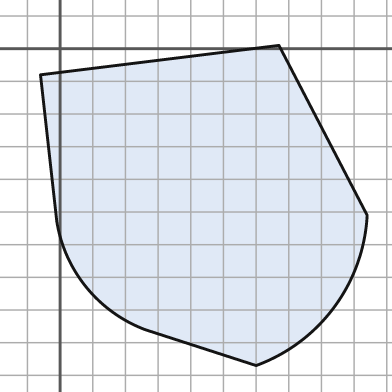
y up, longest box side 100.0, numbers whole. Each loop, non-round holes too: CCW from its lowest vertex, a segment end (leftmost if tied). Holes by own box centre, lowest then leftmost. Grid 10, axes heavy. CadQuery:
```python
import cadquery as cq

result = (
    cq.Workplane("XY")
    .moveTo(60.0, -97.0)
    .threePointArc((84.0, -79.0), (94.0, -51.0))
    .lineTo(67.0, 1.0)
    .lineTo(-6.0, -8.0)
    .lineTo(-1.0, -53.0)
    .threePointArc((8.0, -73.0), (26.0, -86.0))
    .close()
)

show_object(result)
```